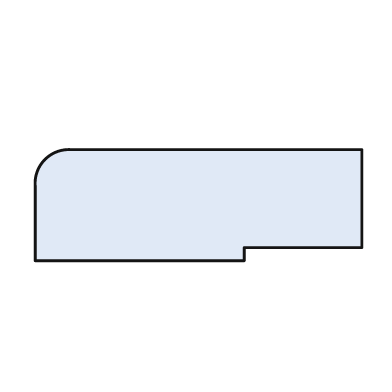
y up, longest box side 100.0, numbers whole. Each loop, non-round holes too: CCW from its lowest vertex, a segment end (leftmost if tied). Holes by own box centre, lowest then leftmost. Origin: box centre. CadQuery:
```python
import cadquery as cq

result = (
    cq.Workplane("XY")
    .moveTo(-50.0, -17.0)
    .lineTo(14.0, -17.0)
    .lineTo(14.0, -13.0)
    .lineTo(50.0, -13.0)
    .lineTo(50.0, 17.0)
    .lineTo(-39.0, 17.0)
    .threePointArc((-47.0, 14.0), (-50.0, 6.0))
    .close()
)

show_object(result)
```